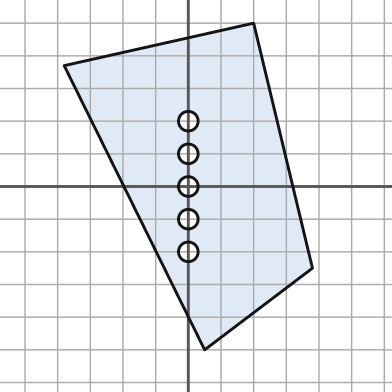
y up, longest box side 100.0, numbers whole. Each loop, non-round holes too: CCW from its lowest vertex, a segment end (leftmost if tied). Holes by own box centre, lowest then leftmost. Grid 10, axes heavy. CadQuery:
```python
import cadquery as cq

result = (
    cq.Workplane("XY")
    .moveTo(5.0, -50.0)
    .lineTo(38.0, -25.0)
    .lineTo(20.0, 50.0)
    .lineTo(-38.0, 37.0)
    .close()
    .moveTo(0.0, -20.0)
    .circle(3.0)
    .moveTo(0.0, -10.0)
    .circle(3.0)
    .moveTo(0.0, 0.0)
    .circle(3.0)
    .moveTo(0.0, 10.0)
    .circle(3.0)
    .moveTo(0.0, 20.0)
    .circle(3.0)
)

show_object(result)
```